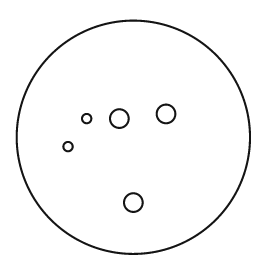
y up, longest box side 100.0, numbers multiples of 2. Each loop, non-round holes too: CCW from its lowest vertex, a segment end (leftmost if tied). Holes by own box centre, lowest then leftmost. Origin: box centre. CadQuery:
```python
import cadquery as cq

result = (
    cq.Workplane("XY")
    .moveTo(0.0, 0.0)
    .circle(50.0)
    .moveTo(0.0, -28.0)
    .circle(4.0)
    .moveTo(-28.0, -4.0)
    .circle(2.0)
    .moveTo(-20.0, 8.0)
    .circle(2.0)
    .moveTo(-6.0, 8.0)
    .circle(4.0)
    .moveTo(14.0, 10.0)
    .circle(4.0)
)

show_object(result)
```